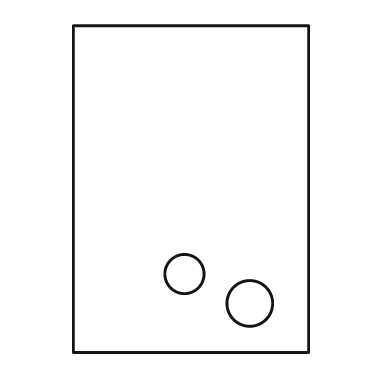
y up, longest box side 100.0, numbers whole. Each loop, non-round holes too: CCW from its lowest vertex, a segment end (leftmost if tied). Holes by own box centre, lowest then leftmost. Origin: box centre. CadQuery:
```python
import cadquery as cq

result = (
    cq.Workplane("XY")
    .moveTo(-36.0, -50.0)
    .lineTo(36.0, -50.0)
    .lineTo(36.0, 50.0)
    .lineTo(-36.0, 50.0)
    .close()
    .moveTo(18.0, -35.0)
    .circle(7.0)
    .moveTo(-2.0, -26.0)
    .circle(6.0)
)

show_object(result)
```